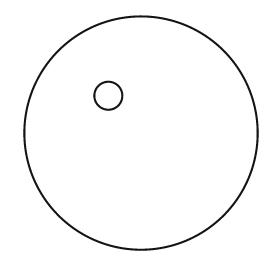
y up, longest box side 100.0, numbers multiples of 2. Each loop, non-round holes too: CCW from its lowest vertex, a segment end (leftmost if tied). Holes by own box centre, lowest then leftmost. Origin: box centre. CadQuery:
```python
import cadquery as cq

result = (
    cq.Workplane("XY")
    .moveTo(0.0, 0.0)
    .circle(50.0)
    .moveTo(-14.0, 16.0)
    .circle(6.0)
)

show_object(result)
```